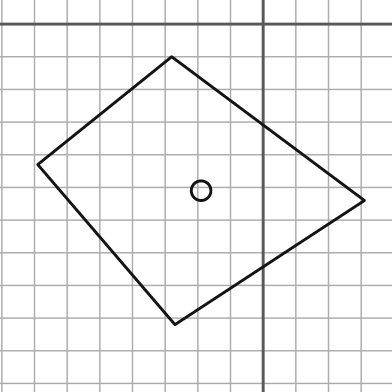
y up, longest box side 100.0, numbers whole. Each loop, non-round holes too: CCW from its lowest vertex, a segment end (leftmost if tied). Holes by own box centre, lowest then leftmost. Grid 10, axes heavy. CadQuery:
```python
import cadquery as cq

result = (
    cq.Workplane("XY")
    .moveTo(-27.0, -92.0)
    .lineTo(31.0, -54.0)
    .lineTo(-28.0, -10.0)
    .lineTo(-69.0, -43.0)
    .close()
    .moveTo(-19.0, -51.0)
    .circle(3.0)
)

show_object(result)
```